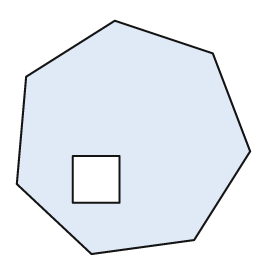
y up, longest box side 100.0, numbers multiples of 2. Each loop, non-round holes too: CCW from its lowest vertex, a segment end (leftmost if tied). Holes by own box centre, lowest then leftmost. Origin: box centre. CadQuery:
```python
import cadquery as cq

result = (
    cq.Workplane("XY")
    .moveTo(-18.0, -50.0)
    .lineTo(26.0, -44.0)
    .lineTo(50.0, -6.0)
    .lineTo(34.0, 36.0)
    .lineTo(-8.0, 50.0)
    .lineTo(-46.0, 26.0)
    .lineTo(-50.0, -20.0)
    .close()
    .moveTo(-26.0, -28.0)
    .lineTo(-6.0, -28.0)
    .lineTo(-6.0, -8.0)
    .lineTo(-26.0, -8.0)
    .close()
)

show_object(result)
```